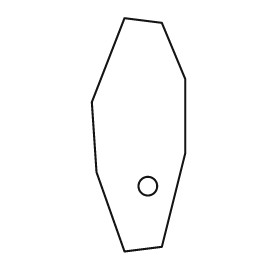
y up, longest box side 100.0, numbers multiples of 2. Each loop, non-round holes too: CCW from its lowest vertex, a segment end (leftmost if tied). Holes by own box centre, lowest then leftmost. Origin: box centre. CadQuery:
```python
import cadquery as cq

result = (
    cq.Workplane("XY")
    .moveTo(-6.0, -50.0)
    .lineTo(10.0, -48.0)
    .lineTo(20.0, -8.0)
    .lineTo(20.0, 24.0)
    .lineTo(10.0, 48.0)
    .lineTo(-6.0, 50.0)
    .lineTo(-20.0, 14.0)
    .lineTo(-18.0, -16.0)
    .close()
    .moveTo(4.0, -22.0)
    .circle(4.0)
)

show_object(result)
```